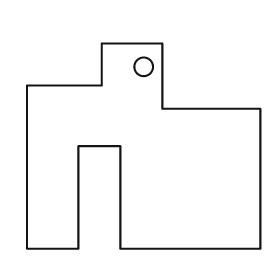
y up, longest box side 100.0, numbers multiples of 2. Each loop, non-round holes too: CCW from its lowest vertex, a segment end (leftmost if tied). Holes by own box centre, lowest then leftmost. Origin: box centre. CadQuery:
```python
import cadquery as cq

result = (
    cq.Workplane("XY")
    .moveTo(-50.0, -44.0)
    .lineTo(-28.0, -44.0)
    .lineTo(-28.0, 0.0)
    .lineTo(-10.0, 0.0)
    .lineTo(-10.0, -44.0)
    .lineTo(50.0, -44.0)
    .lineTo(50.0, 16.0)
    .lineTo(8.0, 16.0)
    .lineTo(8.0, 44.0)
    .lineTo(-18.0, 44.0)
    .lineTo(-18.0, 26.0)
    .lineTo(-50.0, 26.0)
    .close()
    .moveTo(0.0, 34.0)
    .circle(4.0)
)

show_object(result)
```